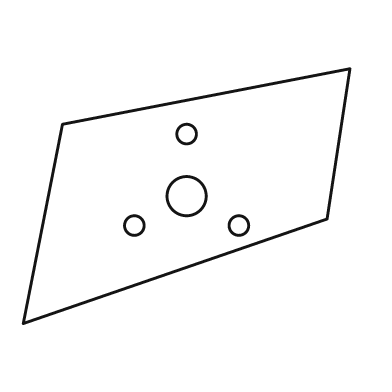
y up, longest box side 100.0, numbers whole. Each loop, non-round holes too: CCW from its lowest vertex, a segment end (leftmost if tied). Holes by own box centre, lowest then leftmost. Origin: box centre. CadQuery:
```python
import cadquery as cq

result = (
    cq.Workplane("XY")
    .moveTo(-50.0, -39.0)
    .lineTo(43.0, -7.0)
    .lineTo(50.0, 39.0)
    .lineTo(-38.0, 22.0)
    .close()
    .moveTo(-16.0, -9.0)
    .circle(3.0)
    .moveTo(16.0, -9.0)
    .circle(3.0)
    .moveTo(0.0, 0.0)
    .circle(6.0)
    .moveTo(0.0, 19.0)
    .circle(3.0)
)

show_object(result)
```